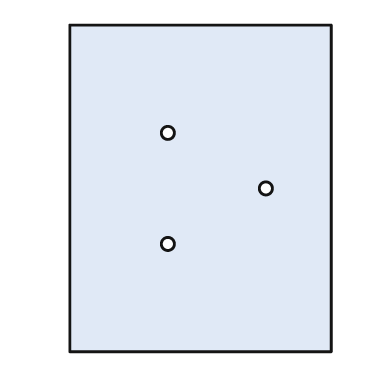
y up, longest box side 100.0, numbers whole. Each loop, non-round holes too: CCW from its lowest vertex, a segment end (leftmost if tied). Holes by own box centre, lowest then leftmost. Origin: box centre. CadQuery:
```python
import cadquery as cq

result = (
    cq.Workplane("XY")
    .moveTo(-40.0, -50.0)
    .lineTo(40.0, -50.0)
    .lineTo(40.0, 50.0)
    .lineTo(-40.0, 50.0)
    .close()
    .moveTo(-10.0, -17.0)
    .circle(2.0)
    .moveTo(20.0, 0.0)
    .circle(2.0)
    .moveTo(-10.0, 17.0)
    .circle(2.0)
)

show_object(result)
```